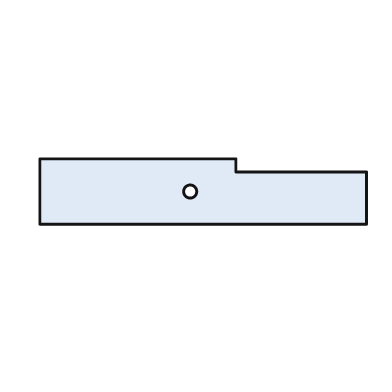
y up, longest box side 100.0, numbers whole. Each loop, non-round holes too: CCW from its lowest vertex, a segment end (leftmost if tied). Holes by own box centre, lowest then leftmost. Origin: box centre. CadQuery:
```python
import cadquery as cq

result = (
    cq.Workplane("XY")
    .moveTo(-50.0, -10.0)
    .lineTo(50.0, -10.0)
    .lineTo(50.0, 6.0)
    .lineTo(10.0, 6.0)
    .lineTo(10.0, 10.0)
    .lineTo(-50.0, 10.0)
    .close()
    .moveTo(-4.0, 0.0)
    .circle(2.0)
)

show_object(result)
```